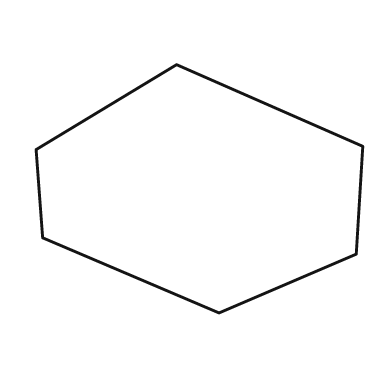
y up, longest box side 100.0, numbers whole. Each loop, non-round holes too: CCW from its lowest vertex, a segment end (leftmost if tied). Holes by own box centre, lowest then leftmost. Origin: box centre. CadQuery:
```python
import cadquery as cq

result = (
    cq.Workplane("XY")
    .moveTo(6.0, -38.0)
    .lineTo(48.0, -20.0)
    .lineTo(50.0, 13.0)
    .lineTo(-7.0, 38.0)
    .lineTo(-50.0, 12.0)
    .lineTo(-48.0, -15.0)
    .close()
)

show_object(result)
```